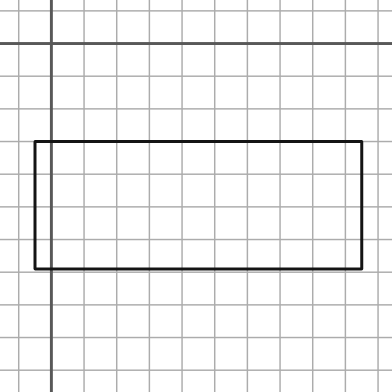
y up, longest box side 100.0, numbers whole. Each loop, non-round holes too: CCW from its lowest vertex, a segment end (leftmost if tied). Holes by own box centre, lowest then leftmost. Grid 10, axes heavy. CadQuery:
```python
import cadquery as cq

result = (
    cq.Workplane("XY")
    .moveTo(-5.0, -69.0)
    .lineTo(95.0, -69.0)
    .lineTo(95.0, -30.0)
    .lineTo(-5.0, -30.0)
    .close()
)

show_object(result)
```